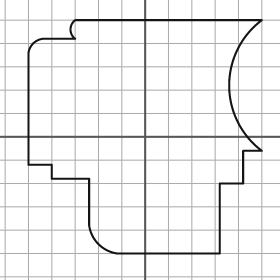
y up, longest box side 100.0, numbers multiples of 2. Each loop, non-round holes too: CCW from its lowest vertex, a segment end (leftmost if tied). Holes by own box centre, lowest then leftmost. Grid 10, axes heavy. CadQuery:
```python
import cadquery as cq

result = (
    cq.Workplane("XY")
    .moveTo(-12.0, -50.0)
    .lineTo(32.0, -50.0)
    .lineTo(32.0, -20.0)
    .lineTo(42.0, -20.0)
    .lineTo(42.0, -6.0)
    .lineTo(50.0, -6.0)
    .threePointArc((36.0, 22.0), (50.0, 50.0))
    .lineTo(-30.0, 50.0)
    .threePointArc((-32.0, 46.0), (-30.0, 42.0))
    .lineTo(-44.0, 42.0)
    .threePointArc((-48.0, 40.0), (-50.0, 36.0))
    .lineTo(-50.0, -12.0)
    .lineTo(-40.0, -12.0)
    .lineTo(-40.0, -18.0)
    .lineTo(-24.0, -18.0)
    .lineTo(-24.0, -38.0)
    .threePointArc((-20.0, -46.0), (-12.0, -50.0))
    .close()
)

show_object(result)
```